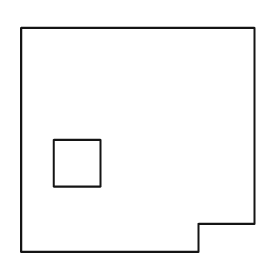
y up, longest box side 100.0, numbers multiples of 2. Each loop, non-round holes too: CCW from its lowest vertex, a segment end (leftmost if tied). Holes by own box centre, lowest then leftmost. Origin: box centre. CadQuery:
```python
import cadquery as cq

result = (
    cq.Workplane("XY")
    .moveTo(-50.0, -48.0)
    .lineTo(26.0, -48.0)
    .lineTo(26.0, -36.0)
    .lineTo(50.0, -36.0)
    .lineTo(50.0, 48.0)
    .lineTo(-50.0, 48.0)
    .close()
    .moveTo(-36.0, -20.0)
    .lineTo(-16.0, -20.0)
    .lineTo(-16.0, 0.0)
    .lineTo(-36.0, 0.0)
    .close()
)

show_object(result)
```